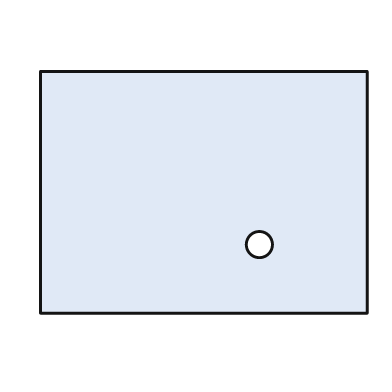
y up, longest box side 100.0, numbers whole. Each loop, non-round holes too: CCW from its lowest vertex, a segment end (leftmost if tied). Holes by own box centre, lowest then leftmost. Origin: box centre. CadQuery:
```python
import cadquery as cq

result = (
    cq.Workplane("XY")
    .moveTo(-50.0, -37.0)
    .lineTo(50.0, -37.0)
    .lineTo(50.0, 37.0)
    .lineTo(-50.0, 37.0)
    .close()
    .moveTo(17.0, -16.0)
    .circle(4.0)
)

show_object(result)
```